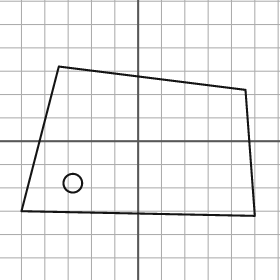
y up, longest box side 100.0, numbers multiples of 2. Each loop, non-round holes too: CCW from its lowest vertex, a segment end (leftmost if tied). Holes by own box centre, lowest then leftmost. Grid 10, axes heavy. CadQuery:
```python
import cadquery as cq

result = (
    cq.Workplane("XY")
    .moveTo(50.0, -32.0)
    .lineTo(46.0, 22.0)
    .lineTo(-34.0, 32.0)
    .lineTo(-50.0, -30.0)
    .close()
    .moveTo(-28.0, -18.0)
    .circle(4.0)
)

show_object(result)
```